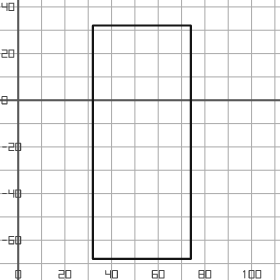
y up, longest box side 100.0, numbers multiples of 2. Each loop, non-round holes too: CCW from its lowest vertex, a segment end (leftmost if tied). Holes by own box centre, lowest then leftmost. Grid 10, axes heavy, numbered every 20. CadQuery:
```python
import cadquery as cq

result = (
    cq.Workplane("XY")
    .moveTo(32.0, -68.0)
    .lineTo(74.0, -68.0)
    .lineTo(74.0, 32.0)
    .lineTo(32.0, 32.0)
    .close()
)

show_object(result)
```